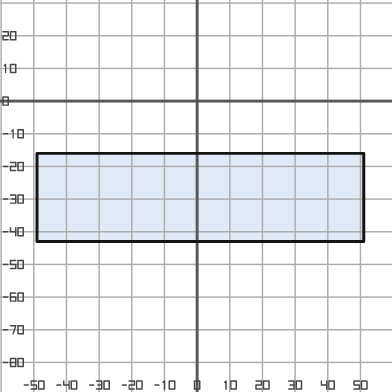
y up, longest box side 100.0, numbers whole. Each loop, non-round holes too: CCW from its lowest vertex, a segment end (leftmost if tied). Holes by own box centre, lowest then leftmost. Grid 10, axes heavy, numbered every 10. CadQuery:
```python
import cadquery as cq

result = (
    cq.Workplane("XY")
    .moveTo(-49.0, -43.0)
    .lineTo(51.0, -43.0)
    .lineTo(51.0, -16.0)
    .lineTo(-49.0, -16.0)
    .close()
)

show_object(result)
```